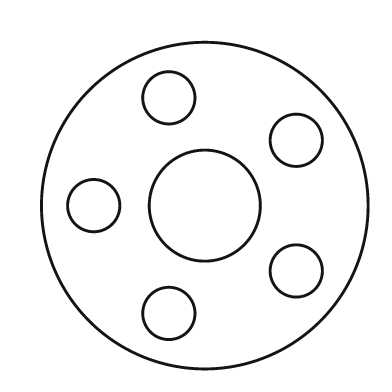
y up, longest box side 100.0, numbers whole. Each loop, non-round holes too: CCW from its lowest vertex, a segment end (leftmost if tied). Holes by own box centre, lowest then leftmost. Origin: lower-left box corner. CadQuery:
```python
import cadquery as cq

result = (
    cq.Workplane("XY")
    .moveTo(50.0, 50.0)
    .circle(50.0)
    .moveTo(39.0, 17.0)
    .circle(8.0)
    .moveTo(78.0, 30.0)
    .circle(8.0)
    .moveTo(16.0, 50.0)
    .circle(8.0)
    .moveTo(50.0, 50.0)
    .circle(17.0)
    .moveTo(78.0, 70.0)
    .circle(8.0)
    .moveTo(39.0, 83.0)
    .circle(8.0)
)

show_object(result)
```